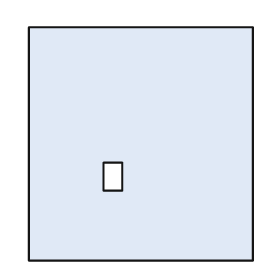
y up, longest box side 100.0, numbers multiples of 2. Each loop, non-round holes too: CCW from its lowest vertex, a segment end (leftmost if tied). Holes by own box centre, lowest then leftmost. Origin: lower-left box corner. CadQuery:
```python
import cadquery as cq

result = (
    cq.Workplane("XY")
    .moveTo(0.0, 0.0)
    .lineTo(96.0, 0.0)
    .lineTo(96.0, 100.0)
    .lineTo(0.0, 100.0)
    .close()
    .moveTo(32.0, 30.0)
    .lineTo(40.0, 30.0)
    .lineTo(40.0, 42.0)
    .lineTo(32.0, 42.0)
    .close()
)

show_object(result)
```